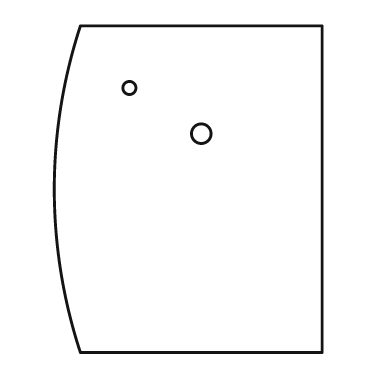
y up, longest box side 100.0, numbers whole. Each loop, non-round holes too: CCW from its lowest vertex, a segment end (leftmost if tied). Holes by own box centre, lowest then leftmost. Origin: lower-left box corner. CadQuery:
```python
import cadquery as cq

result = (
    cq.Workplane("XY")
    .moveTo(8.0, 0.0)
    .lineTo(82.0, 0.0)
    .lineTo(82.0, 100.0)
    .lineTo(8.0, 100.0)
    .threePointArc((0.0, 50.0), (8.0, 0.0))
    .close()
    .moveTo(45.0, 67.0)
    .circle(3.0)
    .moveTo(23.0, 81.0)
    .circle(2.0)
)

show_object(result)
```